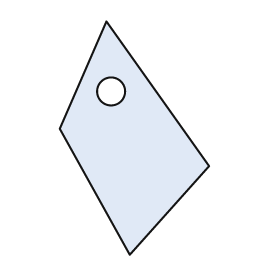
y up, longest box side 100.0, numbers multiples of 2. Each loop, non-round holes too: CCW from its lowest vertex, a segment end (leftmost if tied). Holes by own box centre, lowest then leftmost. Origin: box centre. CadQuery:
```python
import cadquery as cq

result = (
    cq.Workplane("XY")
    .moveTo(-2.0, -50.0)
    .lineTo(32.0, -12.0)
    .lineTo(-12.0, 50.0)
    .lineTo(-32.0, 4.0)
    .close()
    .moveTo(-10.0, 20.0)
    .circle(6.0)
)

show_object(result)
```